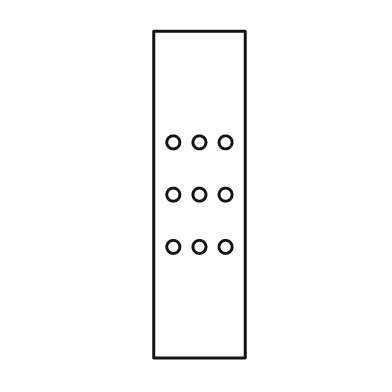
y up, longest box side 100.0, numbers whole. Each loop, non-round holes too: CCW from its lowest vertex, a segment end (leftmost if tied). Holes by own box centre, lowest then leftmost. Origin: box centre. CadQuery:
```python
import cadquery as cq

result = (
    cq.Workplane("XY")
    .moveTo(-14.0, -50.0)
    .lineTo(14.0, -50.0)
    .lineTo(14.0, 50.0)
    .lineTo(-14.0, 50.0)
    .close()
    .moveTo(-8.0, -16.0)
    .circle(2.0)
    .moveTo(0.0, -16.0)
    .circle(2.0)
    .moveTo(8.0, -16.0)
    .circle(2.0)
    .moveTo(-8.0, 0.0)
    .circle(2.0)
    .moveTo(0.0, 0.0)
    .circle(2.0)
    .moveTo(8.0, 0.0)
    .circle(2.0)
    .moveTo(-8.0, 16.0)
    .circle(2.0)
    .moveTo(0.0, 16.0)
    .circle(2.0)
    .moveTo(8.0, 16.0)
    .circle(2.0)
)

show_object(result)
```